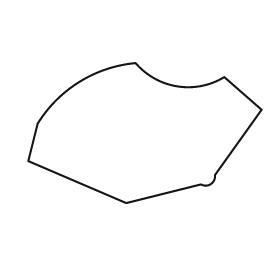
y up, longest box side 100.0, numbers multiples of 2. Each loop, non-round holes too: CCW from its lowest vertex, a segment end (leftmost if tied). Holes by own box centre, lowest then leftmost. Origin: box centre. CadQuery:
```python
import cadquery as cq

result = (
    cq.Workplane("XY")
    .moveTo(-8.0, -30.0)
    .lineTo(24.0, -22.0)
    .threePointArc((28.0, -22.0), (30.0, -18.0))
    .lineTo(50.0, 10.0)
    .lineTo(34.0, 24.0)
    .threePointArc((14.0, 20.0), (-4.0, 30.0))
    .threePointArc((-28.0, 22.0), (-46.0, 4.0))
    .lineTo(-50.0, -12.0)
    .close()
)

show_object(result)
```